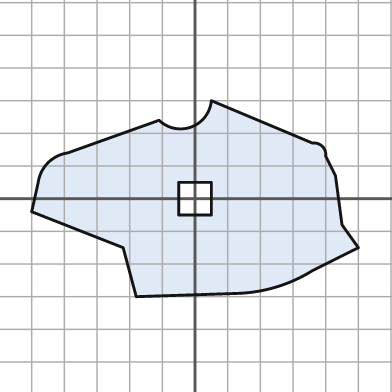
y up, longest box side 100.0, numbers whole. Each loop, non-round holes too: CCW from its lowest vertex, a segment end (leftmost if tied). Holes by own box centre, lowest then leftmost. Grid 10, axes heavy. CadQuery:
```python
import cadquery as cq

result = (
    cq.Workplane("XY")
    .moveTo(-18.0, -30.0)
    .lineTo(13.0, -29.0)
    .threePointArc((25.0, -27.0), (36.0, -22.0))
    .lineTo(50.0, -15.0)
    .lineTo(45.0, -8.0)
    .lineTo(43.0, 7.0)
    .lineTo(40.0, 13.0)
    .threePointArc((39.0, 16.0), (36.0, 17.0))
    .lineTo(5.0, 30.0)
    .threePointArc((-1.0, 22.0), (-11.0, 24.0))
    .lineTo(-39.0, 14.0)
    .threePointArc((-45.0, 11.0), (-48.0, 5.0))
    .lineTo(-50.0, -4.0)
    .lineTo(-22.0, -15.0)
    .close()
    .moveTo(-5.0, -5.0)
    .lineTo(5.0, -5.0)
    .lineTo(5.0, 5.0)
    .lineTo(-5.0, 5.0)
    .close()
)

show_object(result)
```